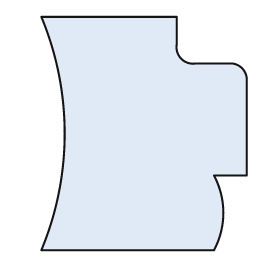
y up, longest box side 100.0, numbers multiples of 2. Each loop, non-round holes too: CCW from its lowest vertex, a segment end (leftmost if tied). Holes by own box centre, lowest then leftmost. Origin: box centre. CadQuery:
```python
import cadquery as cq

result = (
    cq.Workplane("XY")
    .moveTo(-44.0, -50.0)
    .lineTo(30.0, -50.0)
    .threePointArc((34.0, -34.0), (30.0, -18.0))
    .lineTo(44.0, -18.0)
    .lineTo(44.0, 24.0)
    .threePointArc((42.0, 28.0), (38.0, 30.0))
    .lineTo(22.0, 30.0)
    .threePointArc((16.0, 32.0), (14.0, 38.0))
    .lineTo(14.0, 50.0)
    .lineTo(-44.0, 50.0)
    .threePointArc((-34.0, 0.0), (-44.0, -50.0))
    .close()
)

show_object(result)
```